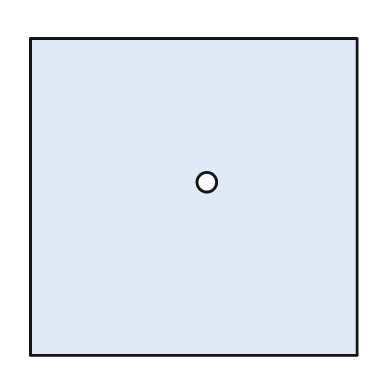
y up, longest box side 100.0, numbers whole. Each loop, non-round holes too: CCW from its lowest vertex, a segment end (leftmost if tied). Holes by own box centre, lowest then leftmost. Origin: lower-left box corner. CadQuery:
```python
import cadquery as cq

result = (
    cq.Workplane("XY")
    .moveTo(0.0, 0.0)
    .lineTo(100.0, 0.0)
    .lineTo(100.0, 97.0)
    .lineTo(0.0, 97.0)
    .close()
    .moveTo(54.0, 53.0)
    .circle(3.0)
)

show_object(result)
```